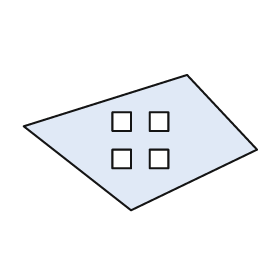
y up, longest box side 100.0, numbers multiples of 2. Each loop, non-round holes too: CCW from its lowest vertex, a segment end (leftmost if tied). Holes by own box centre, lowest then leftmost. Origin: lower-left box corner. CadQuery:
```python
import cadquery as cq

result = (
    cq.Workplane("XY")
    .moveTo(46.0, 0.0)
    .lineTo(100.0, 26.0)
    .lineTo(70.0, 58.0)
    .lineTo(0.0, 36.0)
    .close()
    .moveTo(38.0, 18.0)
    .lineTo(46.0, 18.0)
    .lineTo(46.0, 26.0)
    .lineTo(38.0, 26.0)
    .close()
    .moveTo(54.0, 18.0)
    .lineTo(62.0, 18.0)
    .lineTo(62.0, 26.0)
    .lineTo(54.0, 26.0)
    .close()
    .moveTo(38.0, 34.0)
    .lineTo(46.0, 34.0)
    .lineTo(46.0, 42.0)
    .lineTo(38.0, 42.0)
    .close()
    .moveTo(54.0, 34.0)
    .lineTo(62.0, 34.0)
    .lineTo(62.0, 42.0)
    .lineTo(54.0, 42.0)
    .close()
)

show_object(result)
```